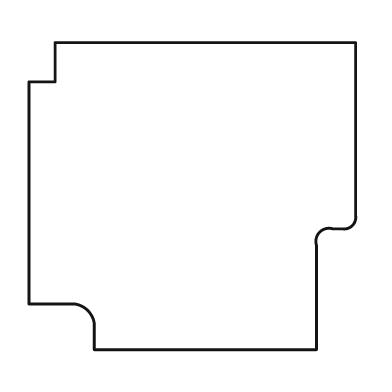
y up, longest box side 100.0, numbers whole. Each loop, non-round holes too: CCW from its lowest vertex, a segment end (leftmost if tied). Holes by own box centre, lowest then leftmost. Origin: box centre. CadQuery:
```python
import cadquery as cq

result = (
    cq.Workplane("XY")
    .moveTo(-30.0, -47.0)
    .lineTo(38.0, -47.0)
    .lineTo(38.0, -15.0)
    .threePointArc((39.0, -11.0), (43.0, -10.0))
    .lineTo(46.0, -10.0)
    .threePointArc((49.0, -9.0), (50.0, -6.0))
    .lineTo(50.0, 47.0)
    .lineTo(-42.0, 47.0)
    .lineTo(-42.0, 35.0)
    .lineTo(-50.0, 35.0)
    .lineTo(-50.0, -33.0)
    .lineTo(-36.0, -33.0)
    .threePointArc((-32.0, -35.0), (-30.0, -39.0))
    .close()
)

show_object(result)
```